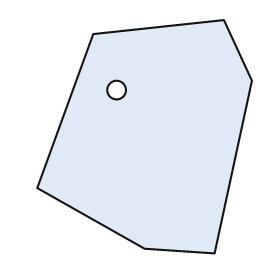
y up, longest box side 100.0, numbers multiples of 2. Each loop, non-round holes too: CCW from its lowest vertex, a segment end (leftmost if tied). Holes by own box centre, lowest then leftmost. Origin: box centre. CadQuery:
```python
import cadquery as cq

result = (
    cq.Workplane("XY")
    .moveTo(30.0, -50.0)
    .lineTo(46.0, 24.0)
    .lineTo(34.0, 50.0)
    .lineTo(-22.0, 44.0)
    .lineTo(-46.0, -22.0)
    .lineTo(0.0, -48.0)
    .close()
    .moveTo(-12.0, 20.0)
    .circle(4.0)
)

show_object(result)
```